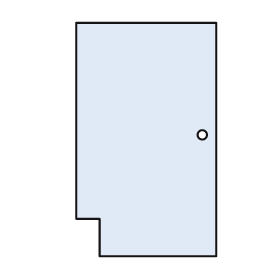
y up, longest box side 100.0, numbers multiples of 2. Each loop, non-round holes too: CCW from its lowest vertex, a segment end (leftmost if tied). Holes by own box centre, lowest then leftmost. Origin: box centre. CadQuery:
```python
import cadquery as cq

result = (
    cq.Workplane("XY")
    .moveTo(-20.0, -50.0)
    .lineTo(30.0, -50.0)
    .lineTo(30.0, 50.0)
    .lineTo(-30.0, 50.0)
    .lineTo(-30.0, -34.0)
    .lineTo(-20.0, -34.0)
    .close()
    .moveTo(24.0, 2.0)
    .circle(2.0)
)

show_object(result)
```